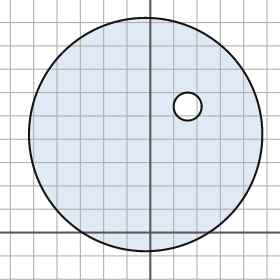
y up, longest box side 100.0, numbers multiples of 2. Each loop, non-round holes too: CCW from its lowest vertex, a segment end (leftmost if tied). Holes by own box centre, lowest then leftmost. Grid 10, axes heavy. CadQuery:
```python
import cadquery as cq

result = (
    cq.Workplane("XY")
    .moveTo(-2.0, 42.0)
    .circle(50.0)
    .moveTo(16.0, 54.0)
    .circle(6.0)
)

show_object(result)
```